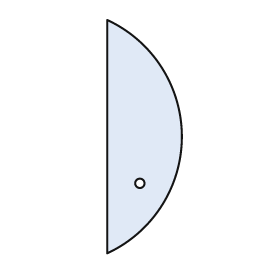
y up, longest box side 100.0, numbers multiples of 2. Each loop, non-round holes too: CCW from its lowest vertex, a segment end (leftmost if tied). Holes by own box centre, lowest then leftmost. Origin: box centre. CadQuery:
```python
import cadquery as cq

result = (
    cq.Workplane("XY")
    .moveTo(-16.0, -50.0)
    .threePointArc((16.0, 0.0), (-16.0, 50.0))
    .close()
    .moveTo(-2.0, -20.0)
    .circle(2.0)
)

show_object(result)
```